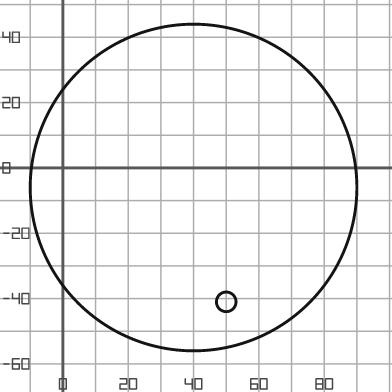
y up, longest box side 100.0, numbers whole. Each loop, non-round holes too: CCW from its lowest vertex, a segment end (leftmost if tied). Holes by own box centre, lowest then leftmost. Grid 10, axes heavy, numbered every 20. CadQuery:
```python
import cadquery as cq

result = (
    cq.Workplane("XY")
    .moveTo(40.0, -6.0)
    .circle(50.0)
    .moveTo(50.0, -41.0)
    .circle(3.0)
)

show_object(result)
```